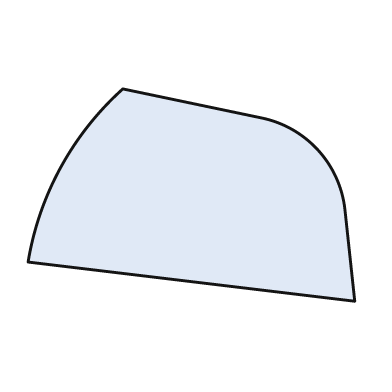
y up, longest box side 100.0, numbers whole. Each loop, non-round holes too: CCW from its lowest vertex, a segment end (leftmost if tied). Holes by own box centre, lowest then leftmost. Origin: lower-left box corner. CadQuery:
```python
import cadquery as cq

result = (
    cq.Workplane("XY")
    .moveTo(100.0, 0.0)
    .lineTo(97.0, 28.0)
    .threePointArc((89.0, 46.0), (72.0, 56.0))
    .lineTo(29.0, 65.0)
    .threePointArc((10.0, 41.0), (0.0, 12.0))
    .close()
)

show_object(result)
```